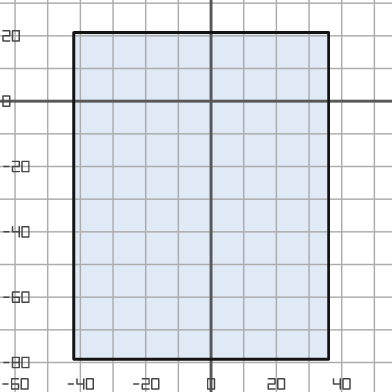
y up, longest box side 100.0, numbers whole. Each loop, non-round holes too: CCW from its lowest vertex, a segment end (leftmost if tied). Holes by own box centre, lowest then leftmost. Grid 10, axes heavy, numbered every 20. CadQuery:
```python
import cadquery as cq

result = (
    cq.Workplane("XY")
    .moveTo(-42.0, -79.0)
    .lineTo(36.0, -79.0)
    .lineTo(36.0, 21.0)
    .lineTo(-42.0, 21.0)
    .close()
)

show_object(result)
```